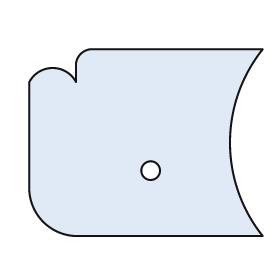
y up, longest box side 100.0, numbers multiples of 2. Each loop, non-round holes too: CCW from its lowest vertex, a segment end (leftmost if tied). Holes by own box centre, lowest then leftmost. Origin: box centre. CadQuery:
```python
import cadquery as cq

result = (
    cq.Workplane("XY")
    .moveTo(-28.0, -40.0)
    .lineTo(50.0, -40.0)
    .threePointArc((36.0, 0.0), (50.0, 40.0))
    .lineTo(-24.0, 40.0)
    .threePointArc((-28.0, 38.0), (-30.0, 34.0))
    .lineTo(-30.0, 26.0)
    .threePointArc((-40.0, 32.0), (-50.0, 26.0))
    .lineTo(-50.0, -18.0)
    .threePointArc((-44.0, -34.0), (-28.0, -40.0))
    .close()
    .moveTo(2.0, -12.0)
    .circle(4.0)
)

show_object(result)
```